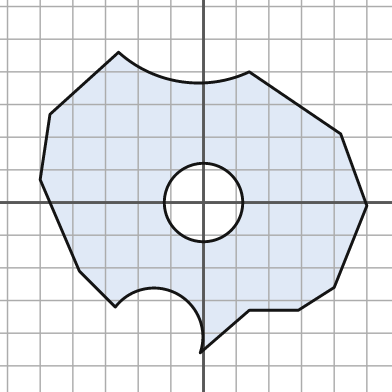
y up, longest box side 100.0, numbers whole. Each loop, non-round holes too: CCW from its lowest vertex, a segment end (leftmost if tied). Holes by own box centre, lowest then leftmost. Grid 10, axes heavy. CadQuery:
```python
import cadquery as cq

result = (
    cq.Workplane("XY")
    .moveTo(-1.0, -46.0)
    .lineTo(14.0, -33.0)
    .lineTo(29.0, -33.0)
    .lineTo(40.0, -26.0)
    .lineTo(50.0, -1.0)
    .lineTo(42.0, 21.0)
    .lineTo(14.0, 40.0)
    .threePointArc((-7.0, 37.0), (-26.0, 46.0))
    .lineTo(-47.0, 27.0)
    .lineTo(-50.0, 7.0)
    .lineTo(-38.0, -21.0)
    .lineTo(-27.0, -32.0)
    .threePointArc((-8.0, -28.0), (-1.0, -46.0))
    .close()
    .moveTo(0.0, 0.0)
    .circle(12.0)
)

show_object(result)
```